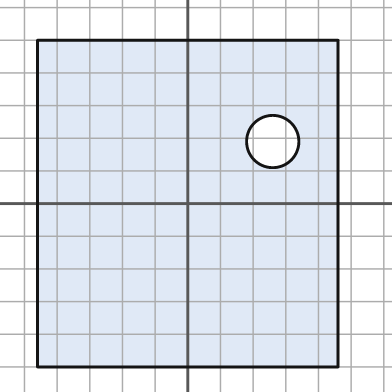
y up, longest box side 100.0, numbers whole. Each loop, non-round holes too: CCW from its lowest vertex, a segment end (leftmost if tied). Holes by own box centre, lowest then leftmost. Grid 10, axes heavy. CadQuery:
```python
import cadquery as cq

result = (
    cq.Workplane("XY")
    .moveTo(-46.0, -50.0)
    .lineTo(46.0, -50.0)
    .lineTo(46.0, 50.0)
    .lineTo(-46.0, 50.0)
    .close()
    .moveTo(26.0, 19.0)
    .circle(8.0)
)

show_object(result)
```